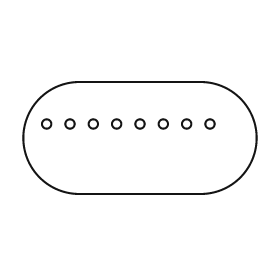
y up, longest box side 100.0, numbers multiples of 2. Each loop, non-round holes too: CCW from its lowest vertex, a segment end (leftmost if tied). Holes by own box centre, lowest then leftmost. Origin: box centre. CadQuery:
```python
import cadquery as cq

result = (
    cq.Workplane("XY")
    .moveTo(-26.0, -24.0)
    .lineTo(26.0, -24.0)
    .threePointArc((50.0, 0.0), (26.0, 24.0))
    .lineTo(-26.0, 24.0)
    .threePointArc((-50.0, 0.0), (-26.0, -24.0))
    .close()
    .moveTo(-40.0, 6.0)
    .circle(2.0)
    .moveTo(-30.0, 6.0)
    .circle(2.0)
    .moveTo(-20.0, 6.0)
    .circle(2.0)
    .moveTo(-10.0, 6.0)
    .circle(2.0)
    .moveTo(0.0, 6.0)
    .circle(2.0)
    .moveTo(10.0, 6.0)
    .circle(2.0)
    .moveTo(20.0, 6.0)
    .circle(2.0)
    .moveTo(30.0, 6.0)
    .circle(2.0)
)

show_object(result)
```